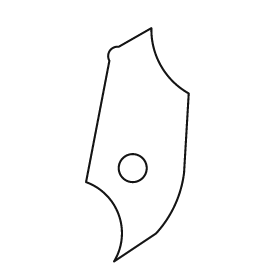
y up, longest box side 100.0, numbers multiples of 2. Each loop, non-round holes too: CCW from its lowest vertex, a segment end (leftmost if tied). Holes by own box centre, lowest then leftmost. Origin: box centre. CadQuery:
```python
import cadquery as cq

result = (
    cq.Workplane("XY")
    .moveTo(-10.0, -50.0)
    .lineTo(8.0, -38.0)
    .threePointArc((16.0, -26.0), (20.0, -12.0))
    .lineTo(22.0, 22.0)
    .threePointArc((10.0, 34.0), (6.0, 50.0))
    .lineTo(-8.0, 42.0)
    .threePointArc((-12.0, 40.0), (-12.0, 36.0))
    .lineTo(-22.0, -16.0)
    .threePointArc((-8.0, -30.0), (-10.0, -50.0))
    .close()
    .moveTo(-2.0, -10.0)
    .circle(6.0)
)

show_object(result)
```